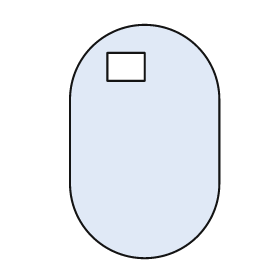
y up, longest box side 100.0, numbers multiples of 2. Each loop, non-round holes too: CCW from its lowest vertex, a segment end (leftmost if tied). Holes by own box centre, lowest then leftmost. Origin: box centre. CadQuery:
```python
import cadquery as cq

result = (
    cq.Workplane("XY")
    .moveTo(-32.0, -18.0)
    .threePointArc((0.0, -50.0), (32.0, -18.0))
    .lineTo(32.0, 18.0)
    .threePointArc((0.0, 50.0), (-32.0, 18.0))
    .close()
    .moveTo(-16.0, 26.0)
    .lineTo(0.0, 26.0)
    .lineTo(0.0, 38.0)
    .lineTo(-16.0, 38.0)
    .close()
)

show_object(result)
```